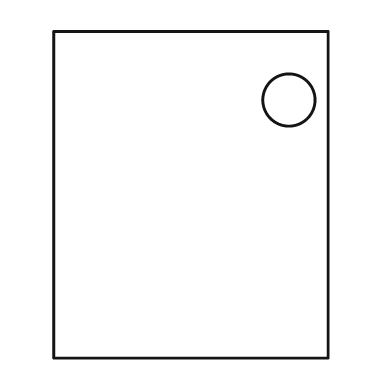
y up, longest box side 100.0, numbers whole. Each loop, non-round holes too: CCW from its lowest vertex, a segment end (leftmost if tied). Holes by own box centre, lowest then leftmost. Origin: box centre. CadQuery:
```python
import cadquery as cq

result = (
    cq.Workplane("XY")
    .moveTo(-42.0, -50.0)
    .lineTo(42.0, -50.0)
    .lineTo(42.0, 50.0)
    .lineTo(-42.0, 50.0)
    .close()
    .moveTo(30.0, 29.0)
    .circle(8.0)
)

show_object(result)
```